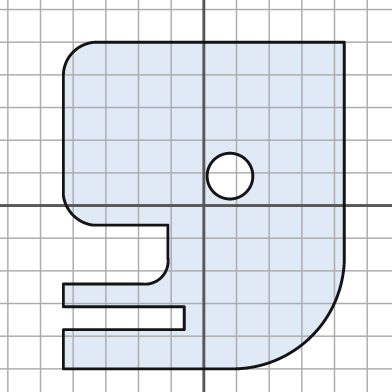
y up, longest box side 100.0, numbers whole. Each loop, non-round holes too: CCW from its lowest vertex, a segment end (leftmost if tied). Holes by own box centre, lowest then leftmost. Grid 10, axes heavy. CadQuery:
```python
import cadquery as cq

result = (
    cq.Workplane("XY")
    .moveTo(-43.0, -50.0)
    .lineTo(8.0, -50.0)
    .threePointArc((33.0, -40.0), (43.0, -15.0))
    .lineTo(43.0, 50.0)
    .lineTo(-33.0, 50.0)
    .threePointArc((-40.0, 47.0), (-43.0, 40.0))
    .lineTo(-43.0, 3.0)
    .threePointArc((-40.0, -3.0), (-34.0, -6.0))
    .lineTo(-11.0, -6.0)
    .lineTo(-11.0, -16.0)
    .threePointArc((-13.0, -22.0), (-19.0, -24.0))
    .lineTo(-43.0, -24.0)
    .lineTo(-43.0, -31.0)
    .lineTo(-6.0, -31.0)
    .lineTo(-6.0, -38.0)
    .lineTo(-43.0, -38.0)
    .close()
    .moveTo(8.0, 9.0)
    .circle(7.0)
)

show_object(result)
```